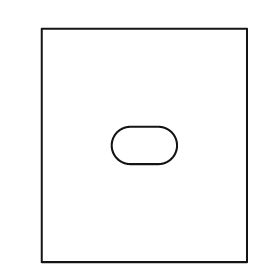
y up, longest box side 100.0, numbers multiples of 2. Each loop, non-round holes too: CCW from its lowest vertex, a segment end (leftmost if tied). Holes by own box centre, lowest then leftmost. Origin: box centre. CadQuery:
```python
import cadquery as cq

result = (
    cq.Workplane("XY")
    .moveTo(-44.0, -50.0)
    .lineTo(44.0, -50.0)
    .lineTo(44.0, 50.0)
    .lineTo(-44.0, 50.0)
    .close()
    .moveTo(-6.0, -8.0)
    .lineTo(6.0, -8.0)
    .threePointArc((14.0, 0.0), (6.0, 8.0))
    .lineTo(-6.0, 8.0)
    .threePointArc((-14.0, 0.0), (-6.0, -8.0))
    .close()
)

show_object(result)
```